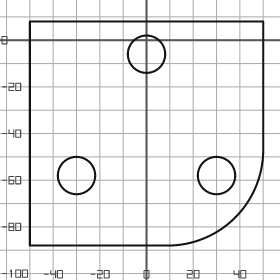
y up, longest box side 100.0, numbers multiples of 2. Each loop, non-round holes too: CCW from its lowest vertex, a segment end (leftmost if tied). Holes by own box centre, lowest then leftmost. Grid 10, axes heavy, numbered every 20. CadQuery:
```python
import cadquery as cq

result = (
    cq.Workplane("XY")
    .moveTo(-50.0, -88.0)
    .lineTo(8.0, -88.0)
    .threePointArc((38.0, -76.0), (50.0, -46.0))
    .lineTo(50.0, 8.0)
    .lineTo(-50.0, 8.0)
    .close()
    .moveTo(-30.0, -58.0)
    .circle(8.0)
    .moveTo(30.0, -58.0)
    .circle(8.0)
    .moveTo(0.0, -6.0)
    .circle(8.0)
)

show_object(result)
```